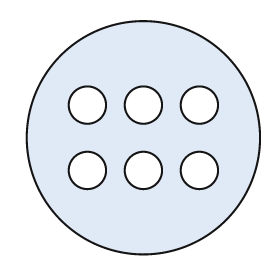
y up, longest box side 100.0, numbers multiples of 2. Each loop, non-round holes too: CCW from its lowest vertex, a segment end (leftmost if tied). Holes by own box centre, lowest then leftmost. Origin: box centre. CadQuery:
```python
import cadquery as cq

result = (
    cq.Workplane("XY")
    .moveTo(0.0, 0.0)
    .circle(50.0)
    .moveTo(-24.0, -14.0)
    .circle(8.0)
    .moveTo(0.0, -14.0)
    .circle(8.0)
    .moveTo(24.0, -14.0)
    .circle(8.0)
    .moveTo(-24.0, 14.0)
    .circle(8.0)
    .moveTo(0.0, 14.0)
    .circle(8.0)
    .moveTo(24.0, 14.0)
    .circle(8.0)
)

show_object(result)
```